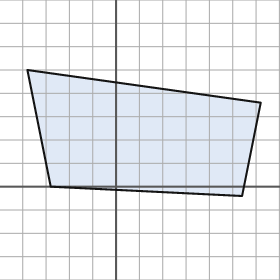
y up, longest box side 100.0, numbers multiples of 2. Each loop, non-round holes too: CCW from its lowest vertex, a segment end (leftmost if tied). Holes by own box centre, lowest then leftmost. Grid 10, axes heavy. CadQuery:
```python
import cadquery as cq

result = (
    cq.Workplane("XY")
    .moveTo(54.0, -4.0)
    .lineTo(62.0, 36.0)
    .lineTo(-38.0, 50.0)
    .lineTo(-28.0, 0.0)
    .close()
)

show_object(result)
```